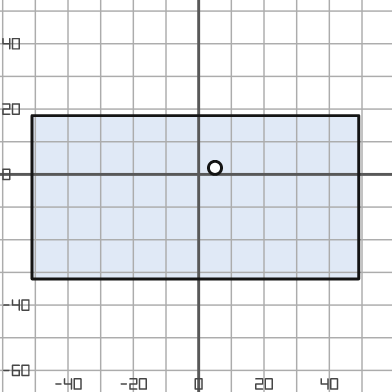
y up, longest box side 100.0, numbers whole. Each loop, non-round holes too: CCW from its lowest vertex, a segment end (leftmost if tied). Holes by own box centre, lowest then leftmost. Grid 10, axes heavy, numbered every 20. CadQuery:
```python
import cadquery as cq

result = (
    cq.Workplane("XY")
    .moveTo(-51.0, -32.0)
    .lineTo(49.0, -32.0)
    .lineTo(49.0, 18.0)
    .lineTo(-51.0, 18.0)
    .close()
    .moveTo(5.0, 2.0)
    .circle(2.0)
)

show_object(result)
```